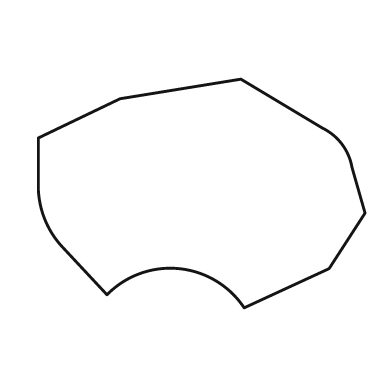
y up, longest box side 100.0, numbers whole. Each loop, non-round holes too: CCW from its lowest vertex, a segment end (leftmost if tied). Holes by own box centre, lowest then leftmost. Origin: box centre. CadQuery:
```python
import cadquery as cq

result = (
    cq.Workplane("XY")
    .moveTo(13.0, -35.0)
    .lineTo(39.0, -23.0)
    .lineTo(50.0, -6.0)
    .lineTo(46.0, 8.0)
    .threePointArc((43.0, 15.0), (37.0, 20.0))
    .lineTo(12.0, 35.0)
    .lineTo(-25.0, 29.0)
    .lineTo(-50.0, 17.0)
    .lineTo(-50.0, 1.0)
    .threePointArc((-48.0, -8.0), (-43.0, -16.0))
    .lineTo(-29.0, -31.0)
    .threePointArc((-7.0, -23.0), (13.0, -35.0))
    .close()
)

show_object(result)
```